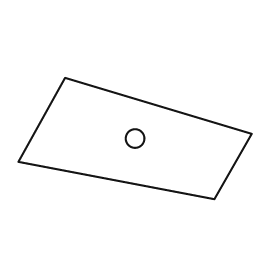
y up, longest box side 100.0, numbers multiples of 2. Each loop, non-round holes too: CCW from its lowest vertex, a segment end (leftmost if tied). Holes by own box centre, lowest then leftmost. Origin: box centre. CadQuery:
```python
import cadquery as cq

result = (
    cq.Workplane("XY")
    .moveTo(34.0, -26.0)
    .lineTo(50.0, 2.0)
    .lineTo(-30.0, 26.0)
    .lineTo(-50.0, -10.0)
    .close()
    .moveTo(0.0, 0.0)
    .circle(4.0)
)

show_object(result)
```